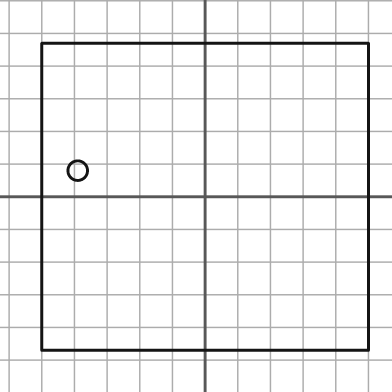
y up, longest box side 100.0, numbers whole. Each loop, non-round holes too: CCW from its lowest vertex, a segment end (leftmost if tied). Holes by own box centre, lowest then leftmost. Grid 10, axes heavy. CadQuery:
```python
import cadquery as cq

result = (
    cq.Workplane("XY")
    .moveTo(-50.0, -47.0)
    .lineTo(50.0, -47.0)
    .lineTo(50.0, 47.0)
    .lineTo(-50.0, 47.0)
    .close()
    .moveTo(-39.0, 8.0)
    .circle(3.0)
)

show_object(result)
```